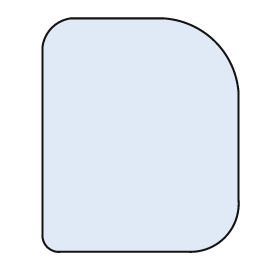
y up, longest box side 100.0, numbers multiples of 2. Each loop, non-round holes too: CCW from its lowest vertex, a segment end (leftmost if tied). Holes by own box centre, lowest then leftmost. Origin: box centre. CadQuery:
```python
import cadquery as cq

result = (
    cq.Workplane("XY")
    .moveTo(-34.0, -50.0)
    .lineTo(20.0, -50.0)
    .threePointArc((36.0, -44.0), (42.0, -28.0))
    .lineTo(42.0, 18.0)
    .threePointArc((32.0, 40.0), (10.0, 50.0))
    .lineTo(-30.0, 50.0)
    .threePointArc((-38.0, 46.0), (-42.0, 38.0))
    .lineTo(-42.0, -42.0)
    .threePointArc((-40.0, -48.0), (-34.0, -50.0))
    .close()
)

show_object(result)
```